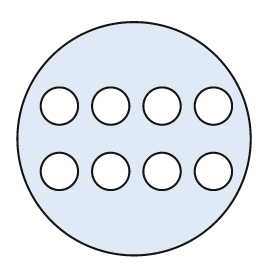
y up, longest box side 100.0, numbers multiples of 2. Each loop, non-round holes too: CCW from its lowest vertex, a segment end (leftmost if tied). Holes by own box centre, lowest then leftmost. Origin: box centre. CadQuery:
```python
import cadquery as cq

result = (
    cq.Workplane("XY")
    .moveTo(0.0, 0.0)
    .circle(50.0)
    .moveTo(-32.0, -14.0)
    .circle(8.0)
    .moveTo(-10.0, -14.0)
    .circle(8.0)
    .moveTo(12.0, -14.0)
    .circle(8.0)
    .moveTo(34.0, -14.0)
    .circle(8.0)
    .moveTo(-32.0, 14.0)
    .circle(8.0)
    .moveTo(-10.0, 14.0)
    .circle(8.0)
    .moveTo(12.0, 14.0)
    .circle(8.0)
    .moveTo(34.0, 14.0)
    .circle(8.0)
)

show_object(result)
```